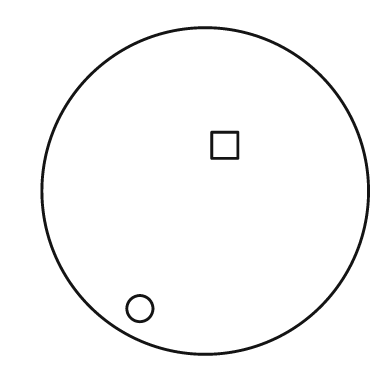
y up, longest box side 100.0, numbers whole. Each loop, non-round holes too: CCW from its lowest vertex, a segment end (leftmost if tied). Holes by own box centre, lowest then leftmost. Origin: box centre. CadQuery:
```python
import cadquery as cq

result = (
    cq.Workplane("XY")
    .moveTo(0.0, 0.0)
    .circle(50.0)
    .moveTo(-20.0, -36.0)
    .circle(4.0)
    .moveTo(2.0, 10.0)
    .lineTo(10.0, 10.0)
    .lineTo(10.0, 18.0)
    .lineTo(2.0, 18.0)
    .close()
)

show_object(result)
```